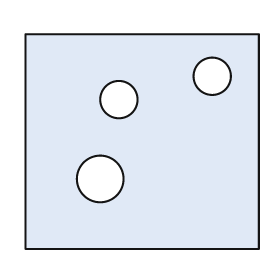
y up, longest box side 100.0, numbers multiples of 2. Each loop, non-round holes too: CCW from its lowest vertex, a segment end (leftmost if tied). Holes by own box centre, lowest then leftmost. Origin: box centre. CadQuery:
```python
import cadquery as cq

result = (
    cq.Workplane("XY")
    .moveTo(-50.0, -46.0)
    .lineTo(50.0, -46.0)
    .lineTo(50.0, 46.0)
    .lineTo(-50.0, 46.0)
    .close()
    .moveTo(-18.0, -16.0)
    .circle(10.0)
    .moveTo(-10.0, 18.0)
    .circle(8.0)
    .moveTo(30.0, 28.0)
    .circle(8.0)
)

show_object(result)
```